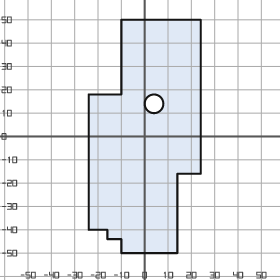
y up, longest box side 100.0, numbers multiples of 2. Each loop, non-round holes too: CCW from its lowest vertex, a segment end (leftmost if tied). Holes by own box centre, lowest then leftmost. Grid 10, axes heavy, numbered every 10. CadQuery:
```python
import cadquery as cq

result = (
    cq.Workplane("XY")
    .moveTo(-10.0, -50.0)
    .lineTo(14.0, -50.0)
    .lineTo(14.0, -16.0)
    .lineTo(24.0, -16.0)
    .lineTo(24.0, 50.0)
    .lineTo(-10.0, 50.0)
    .lineTo(-10.0, 18.0)
    .lineTo(-24.0, 18.0)
    .lineTo(-24.0, -40.0)
    .lineTo(-16.0, -40.0)
    .lineTo(-16.0, -44.0)
    .lineTo(-10.0, -44.0)
    .close()
    .moveTo(4.0, 14.0)
    .circle(4.0)
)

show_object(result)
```